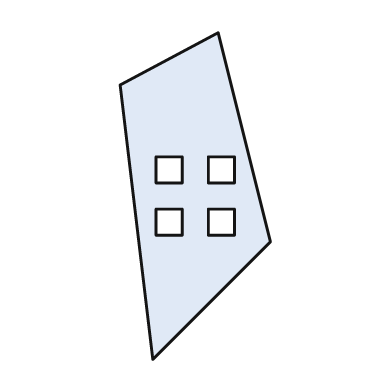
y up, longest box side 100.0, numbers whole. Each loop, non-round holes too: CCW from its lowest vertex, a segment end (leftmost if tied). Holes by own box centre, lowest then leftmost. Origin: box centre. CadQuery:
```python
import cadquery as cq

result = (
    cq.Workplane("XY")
    .moveTo(-13.0, -50.0)
    .lineTo(23.0, -14.0)
    .lineTo(7.0, 50.0)
    .lineTo(-23.0, 34.0)
    .close()
    .moveTo(-12.0, -12.0)
    .lineTo(-4.0, -12.0)
    .lineTo(-4.0, -4.0)
    .lineTo(-12.0, -4.0)
    .close()
    .moveTo(4.0, -12.0)
    .lineTo(12.0, -12.0)
    .lineTo(12.0, -4.0)
    .lineTo(4.0, -4.0)
    .close()
    .moveTo(-12.0, 4.0)
    .lineTo(-4.0, 4.0)
    .lineTo(-4.0, 12.0)
    .lineTo(-12.0, 12.0)
    .close()
    .moveTo(4.0, 4.0)
    .lineTo(12.0, 4.0)
    .lineTo(12.0, 12.0)
    .lineTo(4.0, 12.0)
    .close()
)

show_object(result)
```